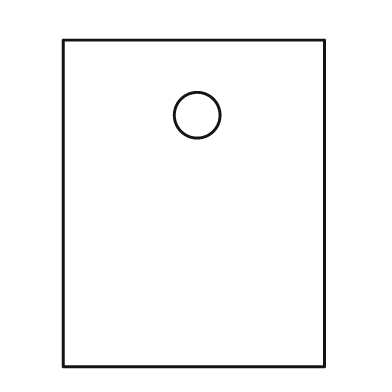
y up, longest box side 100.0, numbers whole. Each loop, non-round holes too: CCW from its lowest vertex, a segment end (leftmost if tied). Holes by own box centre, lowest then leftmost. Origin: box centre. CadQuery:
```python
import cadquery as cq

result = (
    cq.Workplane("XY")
    .moveTo(-40.0, -50.0)
    .lineTo(40.0, -50.0)
    .lineTo(40.0, 50.0)
    .lineTo(-40.0, 50.0)
    .close()
    .moveTo(1.0, 27.0)
    .circle(7.0)
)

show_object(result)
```